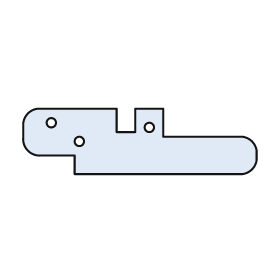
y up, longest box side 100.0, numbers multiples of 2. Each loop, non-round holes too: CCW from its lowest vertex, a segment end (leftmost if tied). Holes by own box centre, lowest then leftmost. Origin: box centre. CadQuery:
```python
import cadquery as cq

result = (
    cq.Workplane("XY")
    .moveTo(-28.0, -14.0)
    .lineTo(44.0, -14.0)
    .threePointArc((48.0, -12.0), (50.0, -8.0))
    .lineTo(50.0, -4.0)
    .threePointArc((48.0, 0.0), (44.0, 2.0))
    .lineTo(10.0, 2.0)
    .lineTo(10.0, 14.0)
    .lineTo(-2.0, 14.0)
    .lineTo(-2.0, 4.0)
    .lineTo(-10.0, 4.0)
    .lineTo(-10.0, 14.0)
    .lineTo(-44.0, 14.0)
    .threePointArc((-48.0, 12.0), (-50.0, 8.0))
    .lineTo(-50.0, 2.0)
    .threePointArc((-48.0, -4.0), (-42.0, -6.0))
    .lineTo(-28.0, -6.0)
    .close()
    .moveTo(-26.0, 0.0)
    .circle(2.0)
    .moveTo(4.0, 6.0)
    .circle(2.0)
    .moveTo(-38.0, 8.0)
    .circle(2.0)
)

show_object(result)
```